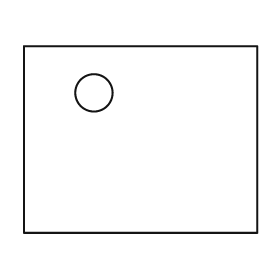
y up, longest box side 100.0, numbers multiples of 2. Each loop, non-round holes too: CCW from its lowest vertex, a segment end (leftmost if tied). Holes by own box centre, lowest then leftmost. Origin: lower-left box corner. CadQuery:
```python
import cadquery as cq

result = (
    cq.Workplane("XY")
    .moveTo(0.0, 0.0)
    .lineTo(100.0, 0.0)
    .lineTo(100.0, 80.0)
    .lineTo(0.0, 80.0)
    .close()
    .moveTo(30.0, 60.0)
    .circle(8.0)
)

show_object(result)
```